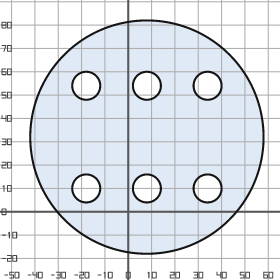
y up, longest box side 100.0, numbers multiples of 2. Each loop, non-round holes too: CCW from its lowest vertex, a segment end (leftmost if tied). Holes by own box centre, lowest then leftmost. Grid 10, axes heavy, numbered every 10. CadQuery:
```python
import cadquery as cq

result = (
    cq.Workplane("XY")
    .moveTo(8.0, 32.0)
    .circle(50.0)
    .moveTo(-18.0, 10.0)
    .circle(6.0)
    .moveTo(8.0, 10.0)
    .circle(6.0)
    .moveTo(34.0, 10.0)
    .circle(6.0)
    .moveTo(-18.0, 54.0)
    .circle(6.0)
    .moveTo(8.0, 54.0)
    .circle(6.0)
    .moveTo(34.0, 54.0)
    .circle(6.0)
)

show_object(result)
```